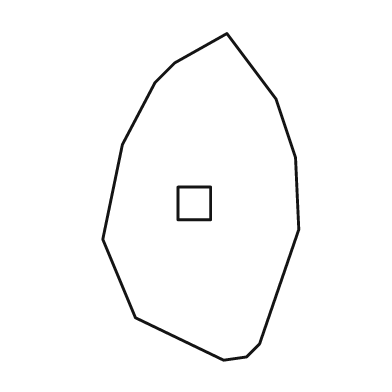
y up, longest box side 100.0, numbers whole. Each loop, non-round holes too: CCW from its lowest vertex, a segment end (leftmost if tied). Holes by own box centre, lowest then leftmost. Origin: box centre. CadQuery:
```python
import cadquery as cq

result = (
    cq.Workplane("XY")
    .moveTo(7.0, -50.0)
    .lineTo(14.0, -49.0)
    .lineTo(18.0, -45.0)
    .lineTo(30.0, -10.0)
    .lineTo(29.0, 12.0)
    .lineTo(23.0, 30.0)
    .lineTo(8.0, 50.0)
    .lineTo(-8.0, 41.0)
    .lineTo(-14.0, 35.0)
    .lineTo(-24.0, 16.0)
    .lineTo(-30.0, -13.0)
    .lineTo(-20.0, -37.0)
    .close()
    .moveTo(-7.0, -7.0)
    .lineTo(3.0, -7.0)
    .lineTo(3.0, 3.0)
    .lineTo(-7.0, 3.0)
    .close()
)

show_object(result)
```